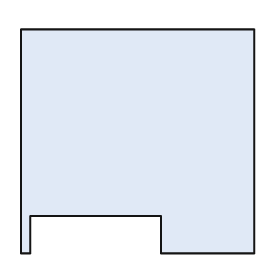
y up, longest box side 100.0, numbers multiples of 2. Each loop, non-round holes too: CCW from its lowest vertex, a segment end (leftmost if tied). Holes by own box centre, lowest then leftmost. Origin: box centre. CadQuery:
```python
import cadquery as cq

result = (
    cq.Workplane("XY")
    .moveTo(-50.0, -48.0)
    .lineTo(-46.0, -48.0)
    .lineTo(-46.0, -32.0)
    .lineTo(10.0, -32.0)
    .lineTo(10.0, -48.0)
    .lineTo(50.0, -48.0)
    .lineTo(50.0, 48.0)
    .lineTo(-50.0, 48.0)
    .close()
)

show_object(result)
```